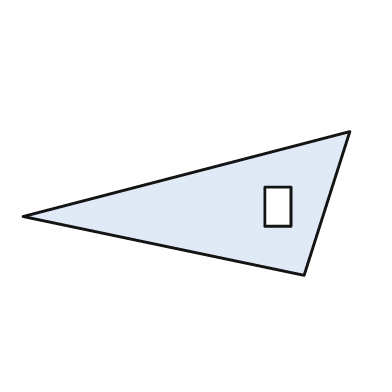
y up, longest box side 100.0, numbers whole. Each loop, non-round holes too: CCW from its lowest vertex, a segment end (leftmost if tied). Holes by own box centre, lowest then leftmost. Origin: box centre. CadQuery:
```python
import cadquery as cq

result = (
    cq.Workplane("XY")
    .moveTo(36.0, -22.0)
    .lineTo(50.0, 22.0)
    .lineTo(-50.0, -4.0)
    .close()
    .moveTo(24.0, -7.0)
    .lineTo(32.0, -7.0)
    .lineTo(32.0, 5.0)
    .lineTo(24.0, 5.0)
    .close()
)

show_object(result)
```